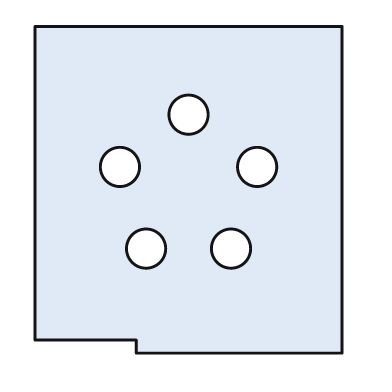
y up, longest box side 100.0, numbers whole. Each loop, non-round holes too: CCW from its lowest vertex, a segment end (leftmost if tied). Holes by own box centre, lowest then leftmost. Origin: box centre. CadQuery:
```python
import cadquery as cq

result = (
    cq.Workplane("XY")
    .moveTo(-16.0, -50.0)
    .lineTo(47.0, -50.0)
    .lineTo(47.0, 50.0)
    .lineTo(-47.0, 50.0)
    .lineTo(-47.0, -46.0)
    .lineTo(-16.0, -46.0)
    .close()
    .moveTo(-13.0, -18.0)
    .circle(6.0)
    .moveTo(13.0, -18.0)
    .circle(6.0)
    .moveTo(-21.0, 7.0)
    .circle(6.0)
    .moveTo(21.0, 7.0)
    .circle(6.0)
    .moveTo(0.0, 23.0)
    .circle(6.0)
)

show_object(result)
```